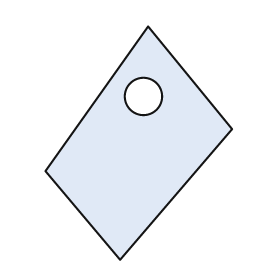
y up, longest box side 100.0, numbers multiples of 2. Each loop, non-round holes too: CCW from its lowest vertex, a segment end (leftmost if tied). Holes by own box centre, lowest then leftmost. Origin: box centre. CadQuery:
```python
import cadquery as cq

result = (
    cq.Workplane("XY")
    .moveTo(-8.0, -50.0)
    .lineTo(40.0, 6.0)
    .lineTo(4.0, 50.0)
    .lineTo(-40.0, -12.0)
    .close()
    .moveTo(2.0, 20.0)
    .circle(8.0)
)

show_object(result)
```